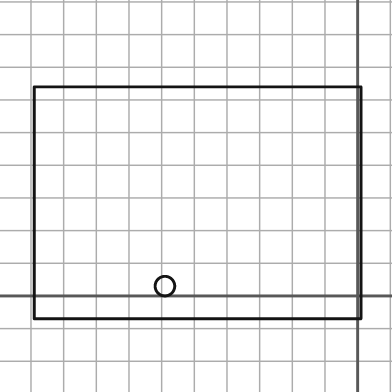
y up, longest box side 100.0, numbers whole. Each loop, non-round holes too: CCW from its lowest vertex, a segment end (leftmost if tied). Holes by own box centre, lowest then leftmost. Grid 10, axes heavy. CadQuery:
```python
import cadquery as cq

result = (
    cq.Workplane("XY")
    .moveTo(-99.0, -7.0)
    .lineTo(1.0, -7.0)
    .lineTo(1.0, 64.0)
    .lineTo(-99.0, 64.0)
    .close()
    .moveTo(-59.0, 3.0)
    .circle(3.0)
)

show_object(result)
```